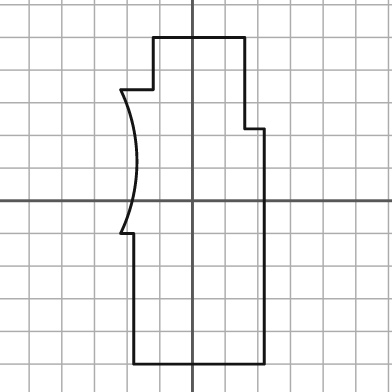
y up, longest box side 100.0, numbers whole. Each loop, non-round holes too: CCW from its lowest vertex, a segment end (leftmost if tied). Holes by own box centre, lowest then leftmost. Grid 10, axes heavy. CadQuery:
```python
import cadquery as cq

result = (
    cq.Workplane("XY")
    .moveTo(-18.0, -50.0)
    .lineTo(22.0, -50.0)
    .lineTo(22.0, 22.0)
    .lineTo(16.0, 22.0)
    .lineTo(16.0, 50.0)
    .lineTo(-12.0, 50.0)
    .lineTo(-12.0, 34.0)
    .lineTo(-22.0, 34.0)
    .threePointArc((-17.0, 12.0), (-22.0, -10.0))
    .lineTo(-18.0, -10.0)
    .close()
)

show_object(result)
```